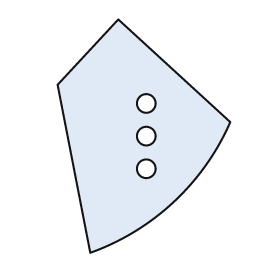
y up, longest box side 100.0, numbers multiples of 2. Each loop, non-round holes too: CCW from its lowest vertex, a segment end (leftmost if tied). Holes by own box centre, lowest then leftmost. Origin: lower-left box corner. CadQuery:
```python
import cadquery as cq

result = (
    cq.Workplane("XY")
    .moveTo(14.0, 0.0)
    .threePointArc((50.0, 22.0), (74.0, 56.0))
    .lineTo(26.0, 100.0)
    .lineTo(0.0, 72.0)
    .close()
    .moveTo(38.0, 36.0)
    .circle(4.0)
    .moveTo(38.0, 50.0)
    .circle(4.0)
    .moveTo(38.0, 64.0)
    .circle(4.0)
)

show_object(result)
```